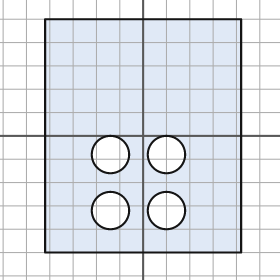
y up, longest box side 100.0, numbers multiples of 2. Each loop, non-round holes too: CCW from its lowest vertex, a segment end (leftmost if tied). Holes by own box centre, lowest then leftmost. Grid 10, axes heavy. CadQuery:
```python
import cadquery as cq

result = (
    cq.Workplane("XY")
    .moveTo(-42.0, -50.0)
    .lineTo(42.0, -50.0)
    .lineTo(42.0, 50.0)
    .lineTo(-42.0, 50.0)
    .close()
    .moveTo(-14.0, -32.0)
    .circle(8.0)
    .moveTo(10.0, -32.0)
    .circle(8.0)
    .moveTo(-14.0, -8.0)
    .circle(8.0)
    .moveTo(10.0, -8.0)
    .circle(8.0)
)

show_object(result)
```